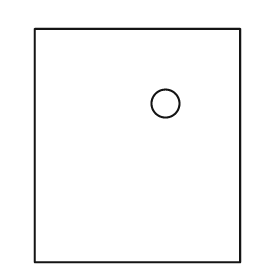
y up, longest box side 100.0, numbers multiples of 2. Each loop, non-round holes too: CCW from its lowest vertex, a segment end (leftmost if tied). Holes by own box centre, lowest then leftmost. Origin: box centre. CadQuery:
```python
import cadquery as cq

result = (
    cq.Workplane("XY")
    .moveTo(-44.0, -50.0)
    .lineTo(44.0, -50.0)
    .lineTo(44.0, 50.0)
    .lineTo(-44.0, 50.0)
    .close()
    .moveTo(12.0, 18.0)
    .circle(6.0)
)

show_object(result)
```